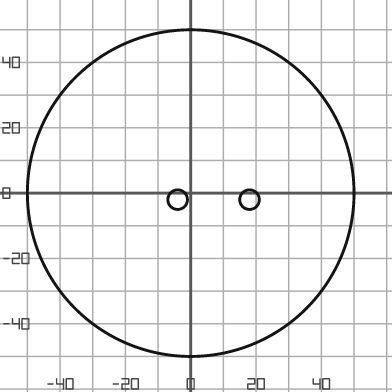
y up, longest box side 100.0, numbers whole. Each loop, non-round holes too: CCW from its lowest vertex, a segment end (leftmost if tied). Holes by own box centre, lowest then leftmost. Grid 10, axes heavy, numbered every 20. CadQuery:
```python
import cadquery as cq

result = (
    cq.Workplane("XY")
    .moveTo(0.0, 0.0)
    .circle(50.0)
    .moveTo(-4.0, -2.0)
    .circle(3.0)
    .moveTo(18.0, -2.0)
    .circle(3.0)
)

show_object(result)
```